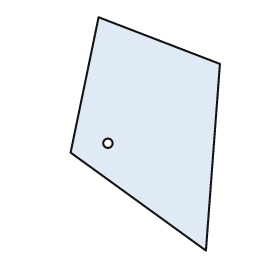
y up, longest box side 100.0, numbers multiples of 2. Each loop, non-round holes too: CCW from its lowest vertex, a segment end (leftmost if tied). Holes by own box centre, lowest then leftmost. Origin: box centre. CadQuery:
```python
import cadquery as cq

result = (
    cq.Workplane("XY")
    .moveTo(26.0, -50.0)
    .lineTo(32.0, 30.0)
    .lineTo(-20.0, 50.0)
    .lineTo(-32.0, -8.0)
    .close()
    .moveTo(-16.0, -4.0)
    .circle(2.0)
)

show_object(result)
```